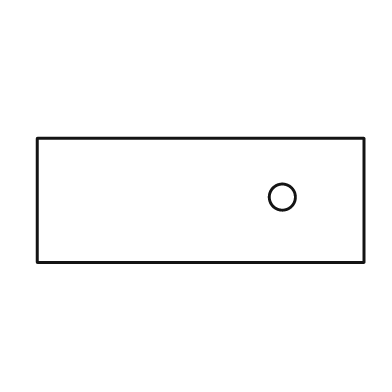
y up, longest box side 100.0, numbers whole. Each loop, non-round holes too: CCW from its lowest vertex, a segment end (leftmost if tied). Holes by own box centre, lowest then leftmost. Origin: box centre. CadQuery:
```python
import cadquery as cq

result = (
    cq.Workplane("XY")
    .moveTo(-50.0, -19.0)
    .lineTo(50.0, -19.0)
    .lineTo(50.0, 19.0)
    .lineTo(-50.0, 19.0)
    .close()
    .moveTo(25.0, 1.0)
    .circle(4.0)
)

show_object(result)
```